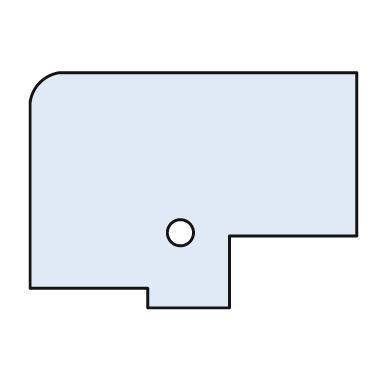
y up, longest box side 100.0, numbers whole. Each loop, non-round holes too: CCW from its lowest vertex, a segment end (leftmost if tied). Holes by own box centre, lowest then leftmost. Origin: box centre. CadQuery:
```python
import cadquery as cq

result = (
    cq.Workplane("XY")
    .moveTo(-14.0, -36.0)
    .lineTo(11.0, -36.0)
    .lineTo(11.0, -14.0)
    .lineTo(50.0, -14.0)
    .lineTo(50.0, 36.0)
    .lineTo(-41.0, 36.0)
    .threePointArc((-47.0, 33.0), (-50.0, 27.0))
    .lineTo(-50.0, -30.0)
    .lineTo(-14.0, -30.0)
    .close()
    .moveTo(-4.0, -13.0)
    .circle(4.0)
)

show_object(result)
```